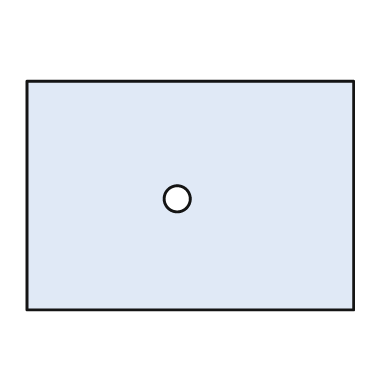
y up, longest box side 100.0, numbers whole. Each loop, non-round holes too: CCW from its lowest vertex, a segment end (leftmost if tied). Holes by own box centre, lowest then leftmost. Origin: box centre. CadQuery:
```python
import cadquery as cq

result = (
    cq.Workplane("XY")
    .moveTo(-50.0, -35.0)
    .lineTo(50.0, -35.0)
    .lineTo(50.0, 35.0)
    .lineTo(-50.0, 35.0)
    .close()
    .moveTo(-4.0, -1.0)
    .circle(4.0)
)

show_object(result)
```